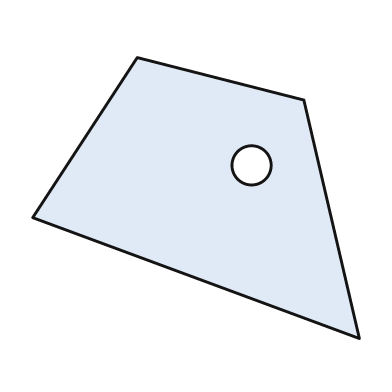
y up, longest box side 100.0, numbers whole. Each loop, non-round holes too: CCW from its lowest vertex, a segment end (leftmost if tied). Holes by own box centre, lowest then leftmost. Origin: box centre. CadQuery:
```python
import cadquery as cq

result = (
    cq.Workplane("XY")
    .moveTo(50.0, -43.0)
    .lineTo(33.0, 30.0)
    .lineTo(-18.0, 43.0)
    .lineTo(-50.0, -6.0)
    .close()
    .moveTo(17.0, 10.0)
    .circle(6.0)
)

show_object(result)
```